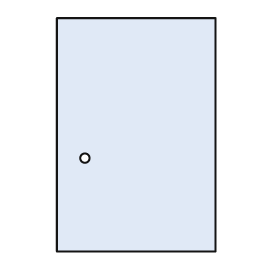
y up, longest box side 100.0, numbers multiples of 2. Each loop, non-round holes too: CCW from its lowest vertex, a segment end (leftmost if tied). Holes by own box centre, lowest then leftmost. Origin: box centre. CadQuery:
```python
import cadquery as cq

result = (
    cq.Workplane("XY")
    .moveTo(-34.0, -50.0)
    .lineTo(34.0, -50.0)
    .lineTo(34.0, 50.0)
    .lineTo(-34.0, 50.0)
    .close()
    .moveTo(-22.0, -10.0)
    .circle(2.0)
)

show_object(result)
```